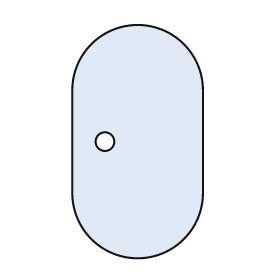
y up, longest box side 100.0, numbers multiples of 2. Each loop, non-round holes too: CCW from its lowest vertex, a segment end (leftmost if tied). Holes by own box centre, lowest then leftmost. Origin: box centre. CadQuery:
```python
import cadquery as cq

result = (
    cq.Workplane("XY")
    .moveTo(-28.0, -22.0)
    .threePointArc((0.0, -50.0), (28.0, -22.0))
    .lineTo(28.0, 22.0)
    .threePointArc((0.0, 50.0), (-28.0, 22.0))
    .close()
    .moveTo(-14.0, 0.0)
    .circle(4.0)
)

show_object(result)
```